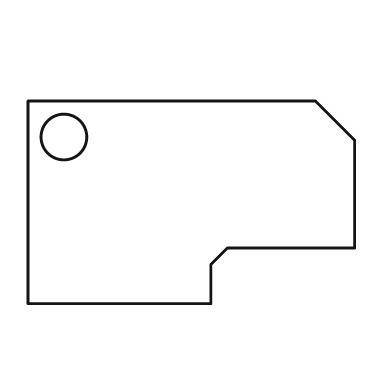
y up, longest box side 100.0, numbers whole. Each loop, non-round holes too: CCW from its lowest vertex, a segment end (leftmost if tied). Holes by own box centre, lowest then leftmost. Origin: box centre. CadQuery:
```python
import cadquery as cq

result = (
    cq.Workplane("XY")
    .moveTo(-50.0, -31.0)
    .lineTo(6.0, -31.0)
    .lineTo(6.0, -19.0)
    .lineTo(11.0, -14.0)
    .lineTo(50.0, -14.0)
    .lineTo(50.0, 19.0)
    .lineTo(38.0, 31.0)
    .lineTo(-50.0, 31.0)
    .close()
    .moveTo(-39.0, 20.0)
    .circle(7.0)
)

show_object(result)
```